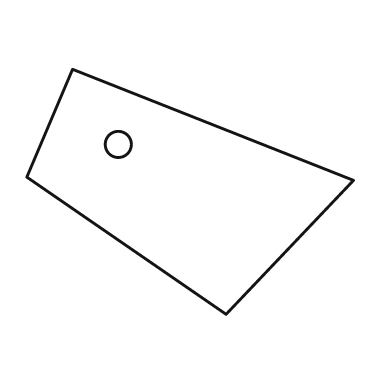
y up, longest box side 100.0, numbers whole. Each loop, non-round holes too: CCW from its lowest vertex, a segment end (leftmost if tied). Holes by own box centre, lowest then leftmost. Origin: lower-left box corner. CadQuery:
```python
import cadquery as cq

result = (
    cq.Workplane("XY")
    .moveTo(61.0, 0.0)
    .lineTo(100.0, 41.0)
    .lineTo(14.0, 75.0)
    .lineTo(0.0, 42.0)
    .close()
    .moveTo(28.0, 52.0)
    .circle(4.0)
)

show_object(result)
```